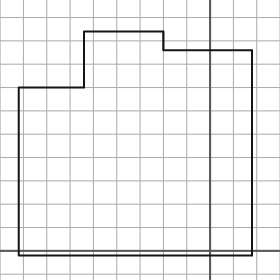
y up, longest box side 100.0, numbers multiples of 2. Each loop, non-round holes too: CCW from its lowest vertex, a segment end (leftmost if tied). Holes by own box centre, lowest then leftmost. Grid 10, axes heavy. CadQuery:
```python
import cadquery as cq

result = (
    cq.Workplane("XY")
    .moveTo(-82.0, -2.0)
    .lineTo(18.0, -2.0)
    .lineTo(18.0, 86.0)
    .lineTo(-20.0, 86.0)
    .lineTo(-20.0, 94.0)
    .lineTo(-54.0, 94.0)
    .lineTo(-54.0, 70.0)
    .lineTo(-82.0, 70.0)
    .close()
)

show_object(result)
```